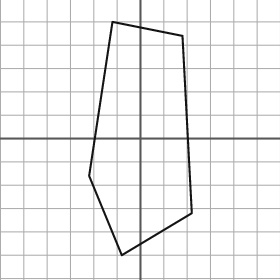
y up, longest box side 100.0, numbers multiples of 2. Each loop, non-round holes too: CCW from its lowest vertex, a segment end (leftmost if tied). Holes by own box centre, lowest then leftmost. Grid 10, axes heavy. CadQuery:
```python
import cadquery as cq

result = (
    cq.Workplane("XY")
    .moveTo(-8.0, -50.0)
    .lineTo(22.0, -32.0)
    .lineTo(18.0, 44.0)
    .lineTo(-12.0, 50.0)
    .lineTo(-22.0, -16.0)
    .close()
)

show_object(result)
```